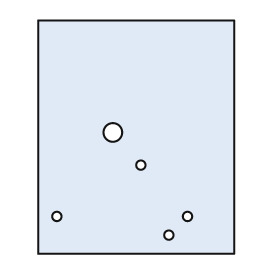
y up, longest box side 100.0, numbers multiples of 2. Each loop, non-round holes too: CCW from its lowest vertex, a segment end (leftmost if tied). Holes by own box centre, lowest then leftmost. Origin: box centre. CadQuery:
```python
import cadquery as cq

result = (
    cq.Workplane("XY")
    .moveTo(-42.0, -50.0)
    .lineTo(42.0, -50.0)
    .lineTo(42.0, 50.0)
    .lineTo(-42.0, 50.0)
    .close()
    .moveTo(14.0, -42.0)
    .circle(2.0)
    .moveTo(-34.0, -34.0)
    .circle(2.0)
    .moveTo(22.0, -34.0)
    .circle(2.0)
    .moveTo(2.0, -12.0)
    .circle(2.0)
    .moveTo(-10.0, 2.0)
    .circle(4.0)
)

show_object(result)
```